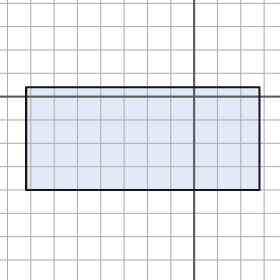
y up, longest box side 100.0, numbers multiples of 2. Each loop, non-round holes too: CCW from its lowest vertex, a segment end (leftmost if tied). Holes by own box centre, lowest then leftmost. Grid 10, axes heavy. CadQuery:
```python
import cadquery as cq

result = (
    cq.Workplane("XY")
    .moveTo(-72.0, -40.0)
    .lineTo(28.0, -40.0)
    .lineTo(28.0, 4.0)
    .lineTo(-72.0, 4.0)
    .close()
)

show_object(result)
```